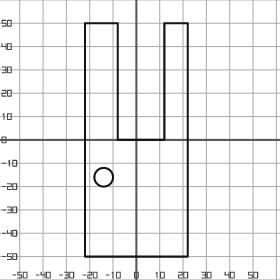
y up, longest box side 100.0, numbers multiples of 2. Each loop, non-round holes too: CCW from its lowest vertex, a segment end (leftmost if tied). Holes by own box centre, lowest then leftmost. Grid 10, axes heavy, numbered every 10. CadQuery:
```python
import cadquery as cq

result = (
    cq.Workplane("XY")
    .moveTo(-22.0, -50.0)
    .lineTo(22.0, -50.0)
    .lineTo(22.0, 50.0)
    .lineTo(12.0, 50.0)
    .lineTo(12.0, 0.0)
    .lineTo(-8.0, 0.0)
    .lineTo(-8.0, 50.0)
    .lineTo(-22.0, 50.0)
    .close()
    .moveTo(-14.0, -16.0)
    .circle(4.0)
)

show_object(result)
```